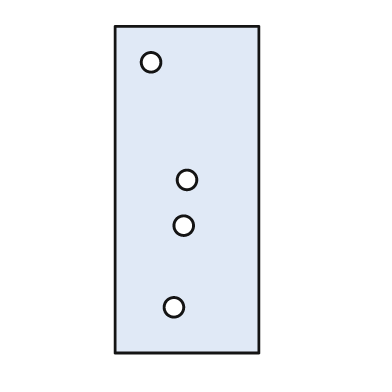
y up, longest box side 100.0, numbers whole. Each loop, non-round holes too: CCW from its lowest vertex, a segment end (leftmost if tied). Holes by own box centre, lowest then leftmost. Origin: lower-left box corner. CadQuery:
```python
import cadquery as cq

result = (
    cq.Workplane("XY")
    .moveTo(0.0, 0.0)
    .lineTo(44.0, 0.0)
    .lineTo(44.0, 100.0)
    .lineTo(0.0, 100.0)
    .close()
    .moveTo(18.0, 14.0)
    .circle(3.0)
    .moveTo(21.0, 39.0)
    .circle(3.0)
    .moveTo(22.0, 53.0)
    .circle(3.0)
    .moveTo(11.0, 89.0)
    .circle(3.0)
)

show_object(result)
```